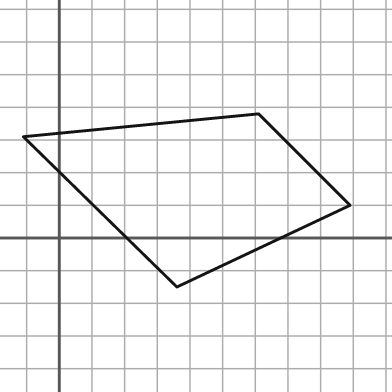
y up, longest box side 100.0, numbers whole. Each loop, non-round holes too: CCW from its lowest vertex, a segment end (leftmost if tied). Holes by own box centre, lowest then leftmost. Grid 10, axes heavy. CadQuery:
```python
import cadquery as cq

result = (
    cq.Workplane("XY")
    .moveTo(36.0, -15.0)
    .lineTo(89.0, 10.0)
    .lineTo(61.0, 38.0)
    .lineTo(-11.0, 31.0)
    .close()
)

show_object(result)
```